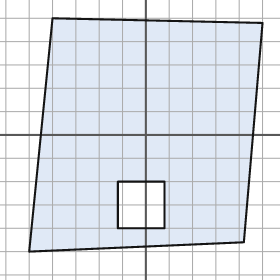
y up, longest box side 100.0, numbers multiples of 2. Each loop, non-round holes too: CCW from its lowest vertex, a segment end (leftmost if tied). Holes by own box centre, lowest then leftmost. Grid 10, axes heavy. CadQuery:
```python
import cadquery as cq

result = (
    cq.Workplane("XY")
    .moveTo(-50.0, -50.0)
    .lineTo(42.0, -46.0)
    .lineTo(50.0, 48.0)
    .lineTo(-40.0, 50.0)
    .close()
    .moveTo(-12.0, -40.0)
    .lineTo(8.0, -40.0)
    .lineTo(8.0, -20.0)
    .lineTo(-12.0, -20.0)
    .close()
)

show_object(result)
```